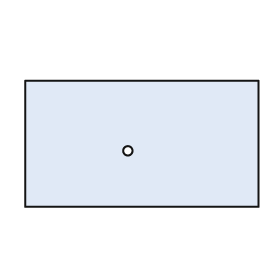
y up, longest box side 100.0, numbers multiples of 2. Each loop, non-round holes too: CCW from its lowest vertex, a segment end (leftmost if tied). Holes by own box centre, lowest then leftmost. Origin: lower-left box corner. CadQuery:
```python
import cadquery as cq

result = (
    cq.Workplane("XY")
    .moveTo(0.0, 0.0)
    .lineTo(100.0, 0.0)
    .lineTo(100.0, 54.0)
    .lineTo(0.0, 54.0)
    .close()
    .moveTo(44.0, 24.0)
    .circle(2.0)
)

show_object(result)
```